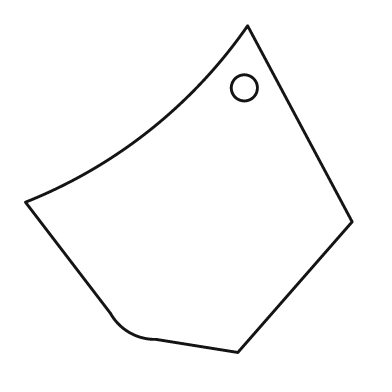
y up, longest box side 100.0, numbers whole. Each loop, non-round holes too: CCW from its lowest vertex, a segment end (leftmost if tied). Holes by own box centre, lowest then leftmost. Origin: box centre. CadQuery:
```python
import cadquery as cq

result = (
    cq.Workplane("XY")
    .moveTo(15.0, -50.0)
    .lineTo(50.0, -10.0)
    .lineTo(18.0, 50.0)
    .threePointArc((-12.0, 18.0), (-50.0, -4.0))
    .lineTo(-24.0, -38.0)
    .threePointArc((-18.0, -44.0), (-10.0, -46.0))
    .close()
    .moveTo(17.0, 31.0)
    .circle(4.0)
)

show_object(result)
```